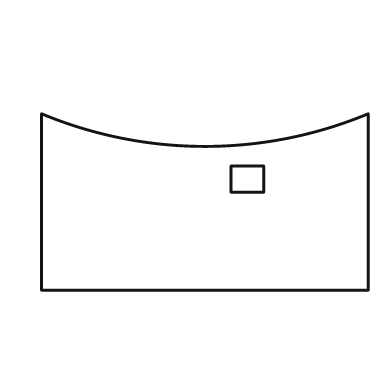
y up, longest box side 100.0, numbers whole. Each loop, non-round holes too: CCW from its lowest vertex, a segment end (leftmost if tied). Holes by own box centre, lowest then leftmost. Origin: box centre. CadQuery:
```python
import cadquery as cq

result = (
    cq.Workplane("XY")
    .moveTo(-50.0, -27.0)
    .lineTo(50.0, -27.0)
    .lineTo(50.0, 27.0)
    .threePointArc((0.0, 17.0), (-50.0, 27.0))
    .close()
    .moveTo(8.0, 3.0)
    .lineTo(18.0, 3.0)
    .lineTo(18.0, 11.0)
    .lineTo(8.0, 11.0)
    .close()
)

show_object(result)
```